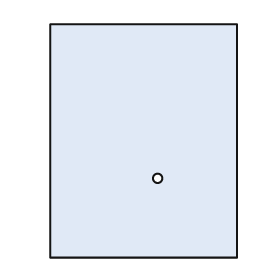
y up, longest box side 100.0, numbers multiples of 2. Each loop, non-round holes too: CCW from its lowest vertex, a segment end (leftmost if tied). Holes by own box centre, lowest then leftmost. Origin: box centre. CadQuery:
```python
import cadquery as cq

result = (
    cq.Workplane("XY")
    .moveTo(-40.0, -50.0)
    .lineTo(40.0, -50.0)
    .lineTo(40.0, 50.0)
    .lineTo(-40.0, 50.0)
    .close()
    .moveTo(6.0, -16.0)
    .circle(2.0)
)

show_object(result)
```